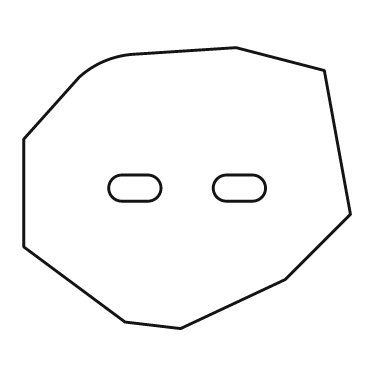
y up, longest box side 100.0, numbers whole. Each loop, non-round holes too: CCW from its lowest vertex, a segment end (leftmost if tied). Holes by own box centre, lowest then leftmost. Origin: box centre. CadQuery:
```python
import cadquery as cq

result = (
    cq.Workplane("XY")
    .moveTo(-2.0, -43.0)
    .lineTo(30.0, -28.0)
    .lineTo(50.0, -8.0)
    .lineTo(42.0, 36.0)
    .lineTo(15.0, 43.0)
    .lineTo(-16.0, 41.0)
    .threePointArc((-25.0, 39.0), (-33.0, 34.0))
    .lineTo(-50.0, 15.0)
    .lineTo(-50.0, -18.0)
    .lineTo(-19.0, -41.0)
    .close()
    .moveTo(-20.0, -4.0)
    .lineTo(-12.0, -4.0)
    .threePointArc((-8.0, 0.0), (-12.0, 4.0))
    .lineTo(-20.0, 4.0)
    .threePointArc((-24.0, 0.0), (-20.0, -4.0))
    .close()
    .moveTo(12.0, -4.0)
    .lineTo(20.0, -4.0)
    .threePointArc((24.0, 0.0), (20.0, 4.0))
    .lineTo(12.0, 4.0)
    .threePointArc((8.0, 0.0), (12.0, -4.0))
    .close()
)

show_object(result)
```